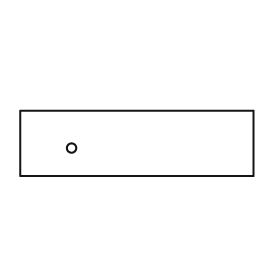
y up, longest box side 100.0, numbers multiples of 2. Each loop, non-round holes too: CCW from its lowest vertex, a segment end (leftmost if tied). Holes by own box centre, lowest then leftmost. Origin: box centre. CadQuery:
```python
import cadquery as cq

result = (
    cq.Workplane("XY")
    .moveTo(-50.0, -14.0)
    .lineTo(50.0, -14.0)
    .lineTo(50.0, 14.0)
    .lineTo(-50.0, 14.0)
    .close()
    .moveTo(-28.0, -2.0)
    .circle(2.0)
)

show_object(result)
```